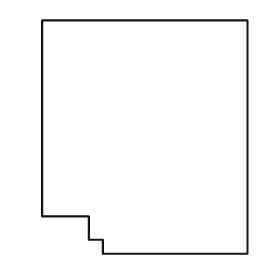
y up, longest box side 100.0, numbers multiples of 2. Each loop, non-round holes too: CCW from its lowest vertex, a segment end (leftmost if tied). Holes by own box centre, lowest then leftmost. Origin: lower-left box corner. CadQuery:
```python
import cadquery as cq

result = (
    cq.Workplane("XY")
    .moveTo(26.0, 0.0)
    .lineTo(88.0, 0.0)
    .lineTo(88.0, 100.0)
    .lineTo(0.0, 100.0)
    .lineTo(0.0, 16.0)
    .lineTo(20.0, 16.0)
    .lineTo(20.0, 6.0)
    .lineTo(26.0, 6.0)
    .close()
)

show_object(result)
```